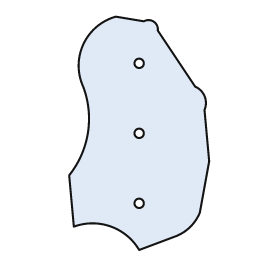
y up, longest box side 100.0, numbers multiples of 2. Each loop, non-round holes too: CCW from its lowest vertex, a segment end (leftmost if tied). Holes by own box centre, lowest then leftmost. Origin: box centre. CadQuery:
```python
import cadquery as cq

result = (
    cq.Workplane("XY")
    .moveTo(0.0, -50.0)
    .lineTo(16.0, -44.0)
    .threePointArc((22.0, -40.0), (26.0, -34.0))
    .lineTo(30.0, -12.0)
    .lineTo(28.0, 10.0)
    .threePointArc((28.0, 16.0), (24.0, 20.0))
    .lineTo(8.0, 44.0)
    .threePointArc((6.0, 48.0), (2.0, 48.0))
    .lineTo(-10.0, 50.0)
    .threePointArc((-24.0, 38.0), (-24.0, 20.0))
    .threePointArc((-22.0, 0.0), (-30.0, -18.0))
    .lineTo(-28.0, -40.0)
    .threePointArc((-12.0, -40.0), (0.0, -50.0))
    .close()
    .moveTo(0.0, -30.0)
    .circle(2.0)
    .moveTo(0.0, 0.0)
    .circle(2.0)
    .moveTo(0.0, 30.0)
    .circle(2.0)
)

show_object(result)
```